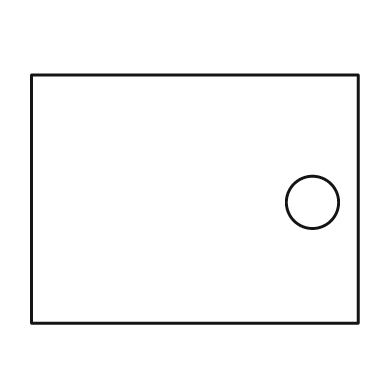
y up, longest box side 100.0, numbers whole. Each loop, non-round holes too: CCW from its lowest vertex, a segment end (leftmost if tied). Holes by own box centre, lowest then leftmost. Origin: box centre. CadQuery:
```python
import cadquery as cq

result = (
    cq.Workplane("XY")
    .moveTo(-50.0, -38.0)
    .lineTo(50.0, -38.0)
    .lineTo(50.0, 38.0)
    .lineTo(-50.0, 38.0)
    .close()
    .moveTo(36.0, -1.0)
    .circle(8.0)
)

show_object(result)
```